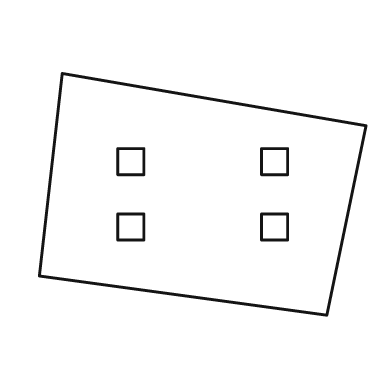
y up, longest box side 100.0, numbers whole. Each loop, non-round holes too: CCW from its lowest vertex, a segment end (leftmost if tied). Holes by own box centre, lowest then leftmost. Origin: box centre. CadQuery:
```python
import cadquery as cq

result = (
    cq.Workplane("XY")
    .moveTo(38.0, -37.0)
    .lineTo(50.0, 21.0)
    .lineTo(-43.0, 37.0)
    .lineTo(-50.0, -25.0)
    .close()
    .moveTo(-26.0, -14.0)
    .lineTo(-18.0, -14.0)
    .lineTo(-18.0, -6.0)
    .lineTo(-26.0, -6.0)
    .close()
    .moveTo(18.0, -14.0)
    .lineTo(26.0, -14.0)
    .lineTo(26.0, -6.0)
    .lineTo(18.0, -6.0)
    .close()
    .moveTo(-26.0, 6.0)
    .lineTo(-18.0, 6.0)
    .lineTo(-18.0, 14.0)
    .lineTo(-26.0, 14.0)
    .close()
    .moveTo(18.0, 6.0)
    .lineTo(26.0, 6.0)
    .lineTo(26.0, 14.0)
    .lineTo(18.0, 14.0)
    .close()
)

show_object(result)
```